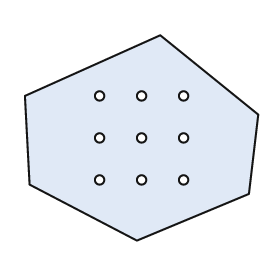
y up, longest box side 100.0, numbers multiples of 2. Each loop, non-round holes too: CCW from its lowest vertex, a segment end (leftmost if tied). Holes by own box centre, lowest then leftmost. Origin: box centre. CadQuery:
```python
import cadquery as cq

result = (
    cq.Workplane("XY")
    .moveTo(-2.0, -44.0)
    .lineTo(46.0, -24.0)
    .lineTo(50.0, 10.0)
    .lineTo(8.0, 44.0)
    .lineTo(-50.0, 18.0)
    .lineTo(-48.0, -20.0)
    .close()
    .moveTo(-18.0, -18.0)
    .circle(2.0)
    .moveTo(0.0, -18.0)
    .circle(2.0)
    .moveTo(18.0, -18.0)
    .circle(2.0)
    .moveTo(-18.0, 0.0)
    .circle(2.0)
    .moveTo(0.0, 0.0)
    .circle(2.0)
    .moveTo(18.0, 0.0)
    .circle(2.0)
    .moveTo(-18.0, 18.0)
    .circle(2.0)
    .moveTo(0.0, 18.0)
    .circle(2.0)
    .moveTo(18.0, 18.0)
    .circle(2.0)
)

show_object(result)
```